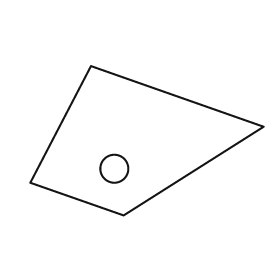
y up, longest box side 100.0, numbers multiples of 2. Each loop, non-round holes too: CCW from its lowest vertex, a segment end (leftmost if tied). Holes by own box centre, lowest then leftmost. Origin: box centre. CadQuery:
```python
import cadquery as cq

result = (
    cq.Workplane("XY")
    .moveTo(-10.0, -32.0)
    .lineTo(50.0, 6.0)
    .lineTo(-24.0, 32.0)
    .lineTo(-50.0, -18.0)
    .close()
    .moveTo(-14.0, -12.0)
    .circle(6.0)
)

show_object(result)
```